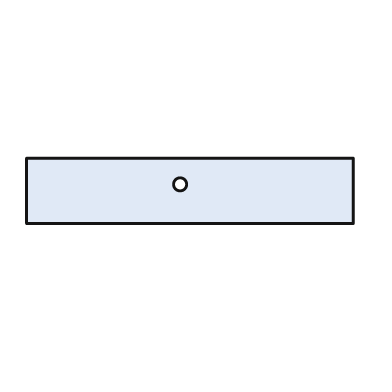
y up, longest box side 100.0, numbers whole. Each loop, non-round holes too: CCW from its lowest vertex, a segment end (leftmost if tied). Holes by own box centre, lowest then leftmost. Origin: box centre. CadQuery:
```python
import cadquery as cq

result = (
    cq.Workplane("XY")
    .moveTo(-50.0, -10.0)
    .lineTo(50.0, -10.0)
    .lineTo(50.0, 10.0)
    .lineTo(-50.0, 10.0)
    .close()
    .moveTo(-3.0, 2.0)
    .circle(2.0)
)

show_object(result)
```